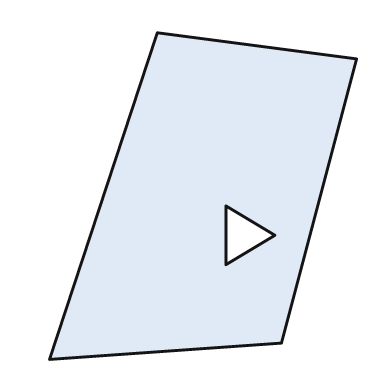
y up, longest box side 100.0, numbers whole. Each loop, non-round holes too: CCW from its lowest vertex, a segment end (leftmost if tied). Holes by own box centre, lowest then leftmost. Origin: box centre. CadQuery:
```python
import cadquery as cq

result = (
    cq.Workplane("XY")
    .moveTo(-47.0, -50.0)
    .lineTo(24.0, -45.0)
    .lineTo(47.0, 42.0)
    .lineTo(-14.0, 50.0)
    .close()
    .moveTo(7.0, -21.0)
    .lineTo(22.0, -12.0)
    .lineTo(7.0, -3.0)
    .close()
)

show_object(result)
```